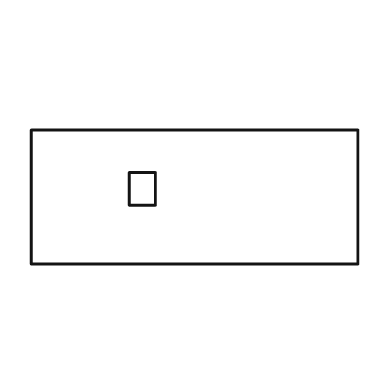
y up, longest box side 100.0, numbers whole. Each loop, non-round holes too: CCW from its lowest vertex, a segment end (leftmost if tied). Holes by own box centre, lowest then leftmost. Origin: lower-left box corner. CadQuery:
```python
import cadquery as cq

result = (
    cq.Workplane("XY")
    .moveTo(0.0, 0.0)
    .lineTo(100.0, 0.0)
    .lineTo(100.0, 41.0)
    .lineTo(0.0, 41.0)
    .close()
    .moveTo(30.0, 18.0)
    .lineTo(38.0, 18.0)
    .lineTo(38.0, 28.0)
    .lineTo(30.0, 28.0)
    .close()
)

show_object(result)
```